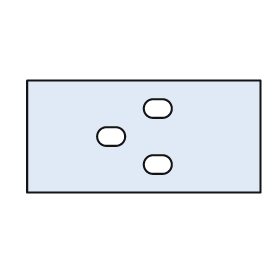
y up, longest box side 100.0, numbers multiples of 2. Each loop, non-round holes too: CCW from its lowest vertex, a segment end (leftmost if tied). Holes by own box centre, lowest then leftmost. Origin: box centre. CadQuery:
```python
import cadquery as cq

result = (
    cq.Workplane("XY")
    .moveTo(-50.0, -24.0)
    .lineTo(50.0, -24.0)
    .lineTo(50.0, 24.0)
    .lineTo(-50.0, 24.0)
    .close()
    .moveTo(4.0, -16.0)
    .lineTo(8.0, -16.0)
    .threePointArc((12.0, -12.0), (8.0, -8.0))
    .lineTo(4.0, -8.0)
    .threePointArc((0.0, -12.0), (4.0, -16.0))
    .close()
    .moveTo(-16.0, -4.0)
    .lineTo(-12.0, -4.0)
    .threePointArc((-8.0, 0.0), (-12.0, 4.0))
    .lineTo(-16.0, 4.0)
    .threePointArc((-20.0, 0.0), (-16.0, -4.0))
    .close()
    .moveTo(4.0, 8.0)
    .lineTo(8.0, 8.0)
    .threePointArc((12.0, 12.0), (8.0, 16.0))
    .lineTo(4.0, 16.0)
    .threePointArc((0.0, 12.0), (4.0, 8.0))
    .close()
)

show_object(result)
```